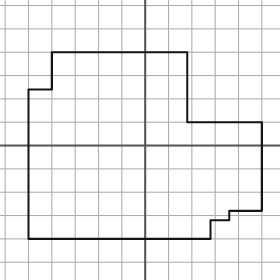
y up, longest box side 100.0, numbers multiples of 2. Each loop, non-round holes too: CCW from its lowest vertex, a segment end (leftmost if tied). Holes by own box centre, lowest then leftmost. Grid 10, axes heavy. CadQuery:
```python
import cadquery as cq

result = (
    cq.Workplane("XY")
    .moveTo(-50.0, -40.0)
    .lineTo(28.0, -40.0)
    .lineTo(28.0, -32.0)
    .lineTo(36.0, -32.0)
    .lineTo(36.0, -28.0)
    .lineTo(50.0, -28.0)
    .lineTo(50.0, 10.0)
    .lineTo(18.0, 10.0)
    .lineTo(18.0, 40.0)
    .lineTo(-40.0, 40.0)
    .lineTo(-40.0, 24.0)
    .lineTo(-50.0, 24.0)
    .close()
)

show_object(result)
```